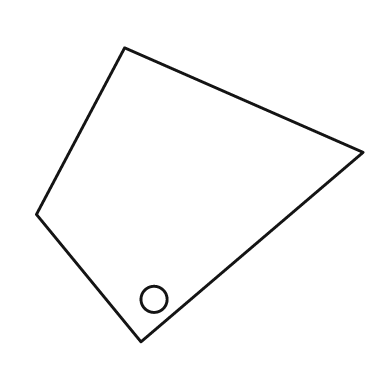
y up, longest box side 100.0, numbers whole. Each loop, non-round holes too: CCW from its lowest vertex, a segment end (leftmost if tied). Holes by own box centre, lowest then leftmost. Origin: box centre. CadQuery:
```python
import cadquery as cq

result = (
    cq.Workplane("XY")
    .moveTo(-18.0, -45.0)
    .lineTo(50.0, 13.0)
    .lineTo(-23.0, 45.0)
    .lineTo(-50.0, -6.0)
    .close()
    .moveTo(-14.0, -32.0)
    .circle(4.0)
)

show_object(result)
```